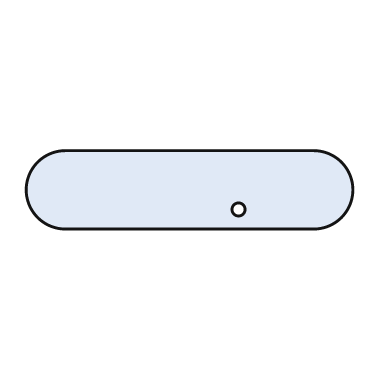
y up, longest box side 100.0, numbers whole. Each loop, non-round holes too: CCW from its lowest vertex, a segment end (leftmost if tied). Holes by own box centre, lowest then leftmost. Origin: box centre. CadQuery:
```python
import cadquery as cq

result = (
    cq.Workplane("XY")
    .moveTo(-38.0, -12.0)
    .lineTo(38.0, -12.0)
    .threePointArc((50.0, 0.0), (38.0, 12.0))
    .lineTo(-38.0, 12.0)
    .threePointArc((-50.0, 0.0), (-38.0, -12.0))
    .close()
    .moveTo(15.0, -6.0)
    .circle(2.0)
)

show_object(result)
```